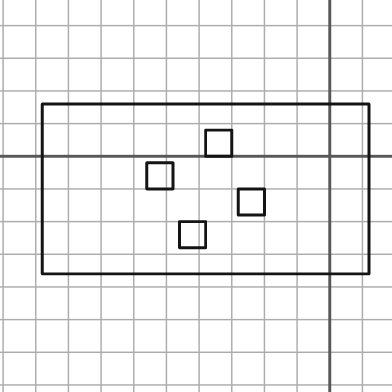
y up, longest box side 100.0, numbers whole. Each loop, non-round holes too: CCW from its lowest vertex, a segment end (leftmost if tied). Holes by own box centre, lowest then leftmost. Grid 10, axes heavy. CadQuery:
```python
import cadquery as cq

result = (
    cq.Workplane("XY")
    .moveTo(-88.0, -36.0)
    .lineTo(12.0, -36.0)
    .lineTo(12.0, 16.0)
    .lineTo(-88.0, 16.0)
    .close()
    .moveTo(-46.0, -28.0)
    .lineTo(-38.0, -28.0)
    .lineTo(-38.0, -20.0)
    .lineTo(-46.0, -20.0)
    .close()
    .moveTo(-28.0, -18.0)
    .lineTo(-20.0, -18.0)
    .lineTo(-20.0, -10.0)
    .lineTo(-28.0, -10.0)
    .close()
    .moveTo(-56.0, -10.0)
    .lineTo(-48.0, -10.0)
    .lineTo(-48.0, -2.0)
    .lineTo(-56.0, -2.0)
    .close()
    .moveTo(-38.0, 0.0)
    .lineTo(-30.0, 0.0)
    .lineTo(-30.0, 8.0)
    .lineTo(-38.0, 8.0)
    .close()
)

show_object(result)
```